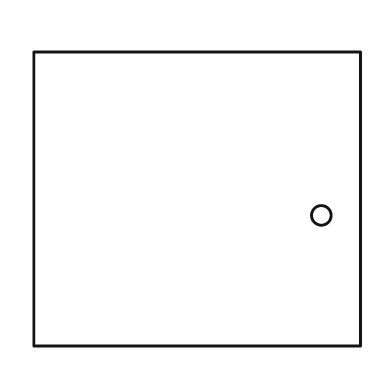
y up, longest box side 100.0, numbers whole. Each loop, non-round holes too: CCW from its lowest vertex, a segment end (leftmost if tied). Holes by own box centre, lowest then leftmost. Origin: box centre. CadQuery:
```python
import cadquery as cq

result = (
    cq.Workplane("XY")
    .moveTo(-50.0, -45.0)
    .lineTo(50.0, -45.0)
    .lineTo(50.0, 45.0)
    .lineTo(-50.0, 45.0)
    .close()
    .moveTo(38.0, -5.0)
    .circle(3.0)
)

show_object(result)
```